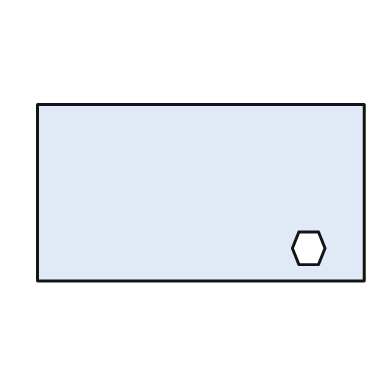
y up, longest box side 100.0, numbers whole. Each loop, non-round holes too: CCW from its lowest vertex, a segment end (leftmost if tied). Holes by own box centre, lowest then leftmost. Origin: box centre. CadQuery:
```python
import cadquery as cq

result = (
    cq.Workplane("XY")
    .moveTo(-50.0, -27.0)
    .lineTo(50.0, -27.0)
    .lineTo(50.0, 27.0)
    .lineTo(-50.0, 27.0)
    .close()
    .moveTo(30.0, -22.0)
    .lineTo(36.0, -22.0)
    .lineTo(38.0, -17.0)
    .lineTo(36.0, -12.0)
    .lineTo(30.0, -12.0)
    .lineTo(28.0, -17.0)
    .close()
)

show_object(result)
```